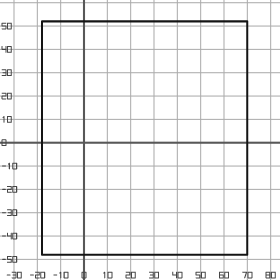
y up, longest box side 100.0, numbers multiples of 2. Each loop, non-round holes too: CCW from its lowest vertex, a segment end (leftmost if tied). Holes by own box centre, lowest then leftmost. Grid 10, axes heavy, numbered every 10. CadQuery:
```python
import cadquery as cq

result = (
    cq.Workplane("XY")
    .moveTo(-18.0, -48.0)
    .lineTo(70.0, -48.0)
    .lineTo(70.0, 52.0)
    .lineTo(-18.0, 52.0)
    .close()
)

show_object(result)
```